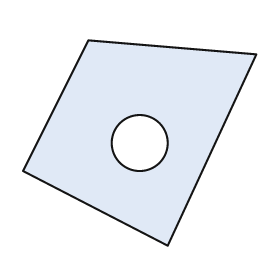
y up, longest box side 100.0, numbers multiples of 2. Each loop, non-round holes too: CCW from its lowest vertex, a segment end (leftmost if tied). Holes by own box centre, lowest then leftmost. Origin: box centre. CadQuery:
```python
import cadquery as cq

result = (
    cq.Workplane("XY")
    .moveTo(12.0, -44.0)
    .lineTo(50.0, 38.0)
    .lineTo(-22.0, 44.0)
    .lineTo(-50.0, -12.0)
    .close()
    .moveTo(0.0, 0.0)
    .circle(12.0)
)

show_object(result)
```